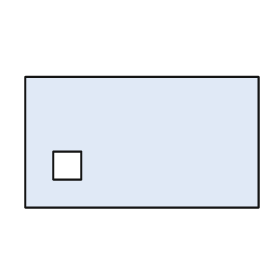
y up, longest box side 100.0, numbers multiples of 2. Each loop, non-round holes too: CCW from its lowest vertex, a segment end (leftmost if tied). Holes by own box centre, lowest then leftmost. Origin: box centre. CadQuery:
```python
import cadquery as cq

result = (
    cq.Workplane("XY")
    .moveTo(-50.0, -28.0)
    .lineTo(50.0, -28.0)
    .lineTo(50.0, 28.0)
    .lineTo(-50.0, 28.0)
    .close()
    .moveTo(-38.0, -16.0)
    .lineTo(-26.0, -16.0)
    .lineTo(-26.0, -4.0)
    .lineTo(-38.0, -4.0)
    .close()
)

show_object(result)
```